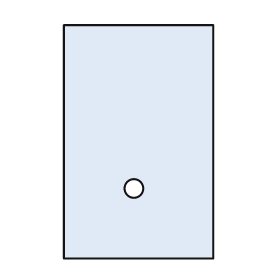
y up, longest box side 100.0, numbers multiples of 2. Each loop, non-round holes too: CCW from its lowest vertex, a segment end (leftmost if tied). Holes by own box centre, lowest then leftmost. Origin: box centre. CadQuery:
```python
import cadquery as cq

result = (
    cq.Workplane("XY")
    .moveTo(-32.0, -50.0)
    .lineTo(32.0, -50.0)
    .lineTo(32.0, 50.0)
    .lineTo(-32.0, 50.0)
    .close()
    .moveTo(-2.0, -20.0)
    .circle(4.0)
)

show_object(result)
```